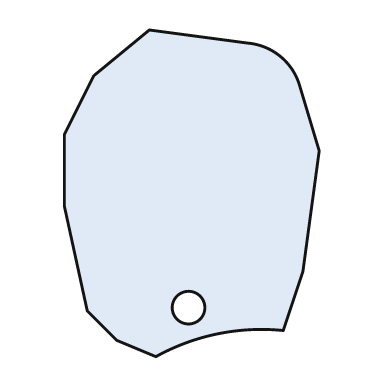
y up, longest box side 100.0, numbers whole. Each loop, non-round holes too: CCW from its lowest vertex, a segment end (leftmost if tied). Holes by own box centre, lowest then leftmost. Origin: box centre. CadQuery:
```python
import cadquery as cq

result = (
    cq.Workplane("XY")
    .moveTo(-11.0, -50.0)
    .threePointArc((8.0, -43.0), (28.0, -42.0))
    .lineTo(34.0, -24.0)
    .lineTo(39.0, 13.0)
    .lineTo(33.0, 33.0)
    .threePointArc((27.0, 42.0), (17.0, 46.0))
    .lineTo(-13.0, 50.0)
    .lineTo(-30.0, 36.0)
    .lineTo(-39.0, 18.0)
    .lineTo(-39.0, -4.0)
    .lineTo(-32.0, -36.0)
    .lineTo(-23.0, -45.0)
    .close()
    .moveTo(-1.0, -35.0)
    .circle(5.0)
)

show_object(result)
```